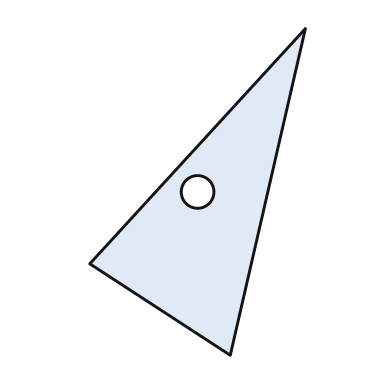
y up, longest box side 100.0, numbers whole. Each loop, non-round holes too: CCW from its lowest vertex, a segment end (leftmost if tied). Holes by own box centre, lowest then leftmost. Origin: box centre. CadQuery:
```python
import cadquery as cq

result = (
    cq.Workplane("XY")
    .moveTo(10.0, -50.0)
    .lineTo(33.0, 50.0)
    .lineTo(-33.0, -22.0)
    .close()
    .moveTo(0.0, 0.0)
    .circle(5.0)
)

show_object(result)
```